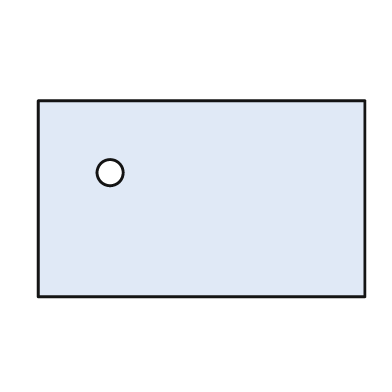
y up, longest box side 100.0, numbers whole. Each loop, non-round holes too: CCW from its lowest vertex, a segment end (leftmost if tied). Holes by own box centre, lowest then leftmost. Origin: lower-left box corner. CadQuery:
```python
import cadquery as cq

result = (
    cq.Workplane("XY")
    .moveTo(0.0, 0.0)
    .lineTo(100.0, 0.0)
    .lineTo(100.0, 60.0)
    .lineTo(0.0, 60.0)
    .close()
    .moveTo(22.0, 38.0)
    .circle(4.0)
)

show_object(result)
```